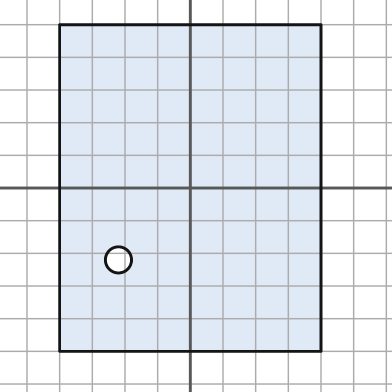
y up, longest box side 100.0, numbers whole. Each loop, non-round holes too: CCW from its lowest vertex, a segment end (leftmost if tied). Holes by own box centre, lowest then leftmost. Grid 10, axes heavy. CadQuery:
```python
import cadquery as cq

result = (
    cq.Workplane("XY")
    .moveTo(-40.0, -50.0)
    .lineTo(40.0, -50.0)
    .lineTo(40.0, 50.0)
    .lineTo(-40.0, 50.0)
    .close()
    .moveTo(-22.0, -22.0)
    .circle(4.0)
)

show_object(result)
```